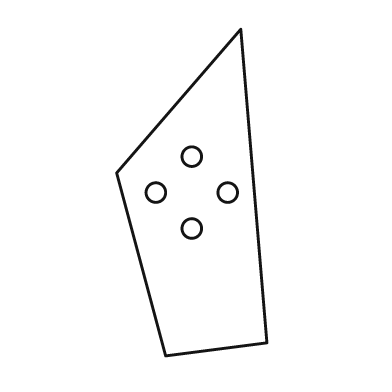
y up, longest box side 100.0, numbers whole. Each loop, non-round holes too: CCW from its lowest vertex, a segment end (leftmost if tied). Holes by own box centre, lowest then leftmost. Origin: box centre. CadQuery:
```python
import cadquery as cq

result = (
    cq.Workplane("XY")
    .moveTo(-8.0, -50.0)
    .lineTo(23.0, -46.0)
    .lineTo(15.0, 50.0)
    .lineTo(-23.0, 6.0)
    .close()
    .moveTo(0.0, -11.0)
    .circle(3.0)
    .moveTo(-11.0, 0.0)
    .circle(3.0)
    .moveTo(11.0, 0.0)
    .circle(3.0)
    .moveTo(0.0, 11.0)
    .circle(3.0)
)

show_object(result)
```